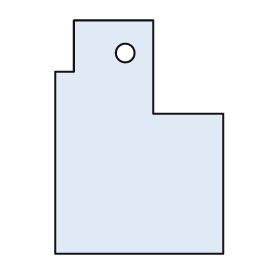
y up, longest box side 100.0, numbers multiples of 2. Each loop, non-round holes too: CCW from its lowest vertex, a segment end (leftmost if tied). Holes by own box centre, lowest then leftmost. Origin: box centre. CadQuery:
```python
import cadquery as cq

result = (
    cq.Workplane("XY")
    .moveTo(-36.0, -50.0)
    .lineTo(36.0, -50.0)
    .lineTo(36.0, 10.0)
    .lineTo(6.0, 10.0)
    .lineTo(6.0, 50.0)
    .lineTo(-28.0, 50.0)
    .lineTo(-28.0, 28.0)
    .lineTo(-36.0, 28.0)
    .close()
    .moveTo(-6.0, 36.0)
    .circle(4.0)
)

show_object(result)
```